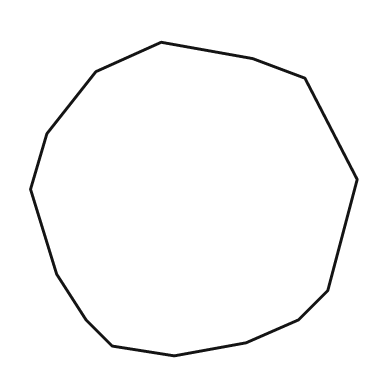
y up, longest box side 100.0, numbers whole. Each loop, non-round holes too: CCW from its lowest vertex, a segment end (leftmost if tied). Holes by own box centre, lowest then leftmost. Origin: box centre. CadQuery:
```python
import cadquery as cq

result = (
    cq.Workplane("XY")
    .moveTo(-6.0, -48.0)
    .lineTo(16.0, -44.0)
    .lineTo(32.0, -37.0)
    .lineTo(41.0, -28.0)
    .lineTo(50.0, 6.0)
    .lineTo(34.0, 37.0)
    .lineTo(18.0, 43.0)
    .lineTo(-10.0, 48.0)
    .lineTo(-30.0, 39.0)
    .lineTo(-45.0, 20.0)
    .lineTo(-50.0, 3.0)
    .lineTo(-42.0, -23.0)
    .lineTo(-33.0, -37.0)
    .lineTo(-25.0, -45.0)
    .close()
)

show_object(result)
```